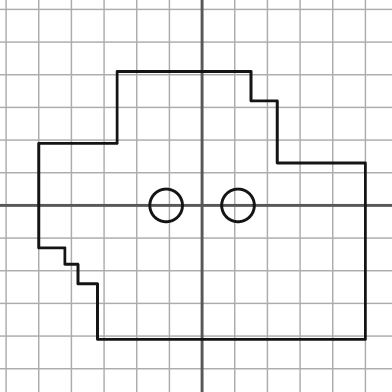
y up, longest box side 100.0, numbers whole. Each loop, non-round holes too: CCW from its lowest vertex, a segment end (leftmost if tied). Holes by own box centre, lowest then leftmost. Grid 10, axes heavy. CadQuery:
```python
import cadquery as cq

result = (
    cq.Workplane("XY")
    .moveTo(-32.0, -41.0)
    .lineTo(50.0, -41.0)
    .lineTo(50.0, 13.0)
    .lineTo(23.0, 13.0)
    .lineTo(23.0, 32.0)
    .lineTo(15.0, 32.0)
    .lineTo(15.0, 41.0)
    .lineTo(-26.0, 41.0)
    .lineTo(-26.0, 19.0)
    .lineTo(-50.0, 19.0)
    .lineTo(-50.0, -13.0)
    .lineTo(-42.0, -13.0)
    .lineTo(-42.0, -18.0)
    .lineTo(-38.0, -18.0)
    .lineTo(-38.0, -24.0)
    .lineTo(-32.0, -24.0)
    .close()
    .moveTo(-11.0, 0.0)
    .circle(5.0)
    .moveTo(11.0, 0.0)
    .circle(5.0)
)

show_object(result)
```